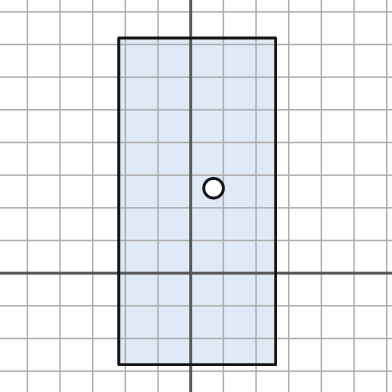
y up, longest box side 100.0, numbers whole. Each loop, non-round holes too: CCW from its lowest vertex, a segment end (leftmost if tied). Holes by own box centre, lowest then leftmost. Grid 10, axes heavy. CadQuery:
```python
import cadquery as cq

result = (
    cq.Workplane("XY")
    .moveTo(-22.0, -28.0)
    .lineTo(26.0, -28.0)
    .lineTo(26.0, 72.0)
    .lineTo(-22.0, 72.0)
    .close()
    .moveTo(7.0, 26.0)
    .circle(3.0)
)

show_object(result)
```